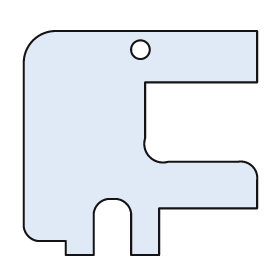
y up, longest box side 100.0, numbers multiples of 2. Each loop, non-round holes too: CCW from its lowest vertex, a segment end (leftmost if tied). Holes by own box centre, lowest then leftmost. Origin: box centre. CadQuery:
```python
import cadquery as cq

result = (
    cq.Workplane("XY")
    .moveTo(-32.0, -48.0)
    .lineTo(-20.0, -48.0)
    .lineTo(-20.0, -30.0)
    .threePointArc((-18.0, -26.0), (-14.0, -24.0))
    .lineTo(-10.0, -24.0)
    .threePointArc((-6.0, -26.0), (-4.0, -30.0))
    .lineTo(-4.0, -48.0)
    .lineTo(8.0, -48.0)
    .lineTo(8.0, -28.0)
    .lineTo(50.0, -28.0)
    .lineTo(50.0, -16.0)
    .threePointArc((48.0, -10.0), (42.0, -8.0))
    .lineTo(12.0, -8.0)
    .threePointArc((4.0, -6.0), (2.0, 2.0))
    .lineTo(2.0, 26.0)
    .lineTo(50.0, 26.0)
    .lineTo(50.0, 48.0)
    .lineTo(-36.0, 48.0)
    .threePointArc((-46.0, 44.0), (-50.0, 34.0))
    .lineTo(-50.0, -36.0)
    .threePointArc((-48.0, -40.0), (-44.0, -42.0))
    .lineTo(-32.0, -42.0)
    .close()
    .moveTo(0.0, 40.0)
    .circle(4.0)
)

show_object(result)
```